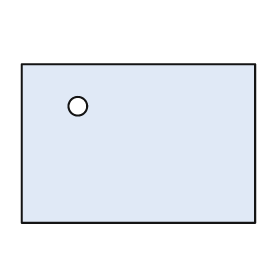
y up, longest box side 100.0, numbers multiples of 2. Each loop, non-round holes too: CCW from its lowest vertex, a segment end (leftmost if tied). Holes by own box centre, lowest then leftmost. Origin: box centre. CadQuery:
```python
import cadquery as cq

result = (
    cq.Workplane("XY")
    .moveTo(-50.0, -34.0)
    .lineTo(50.0, -34.0)
    .lineTo(50.0, 34.0)
    .lineTo(-50.0, 34.0)
    .close()
    .moveTo(-26.0, 16.0)
    .circle(4.0)
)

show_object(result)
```